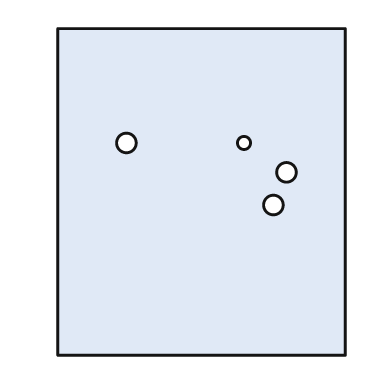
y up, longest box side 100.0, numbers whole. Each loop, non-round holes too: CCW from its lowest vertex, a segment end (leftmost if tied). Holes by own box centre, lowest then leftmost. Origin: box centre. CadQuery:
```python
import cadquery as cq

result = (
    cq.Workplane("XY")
    .moveTo(-44.0, -50.0)
    .lineTo(44.0, -50.0)
    .lineTo(44.0, 50.0)
    .lineTo(-44.0, 50.0)
    .close()
    .moveTo(22.0, -4.0)
    .circle(3.0)
    .moveTo(26.0, 6.0)
    .circle(3.0)
    .moveTo(-23.0, 15.0)
    .circle(3.0)
    .moveTo(13.0, 15.0)
    .circle(2.0)
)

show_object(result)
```